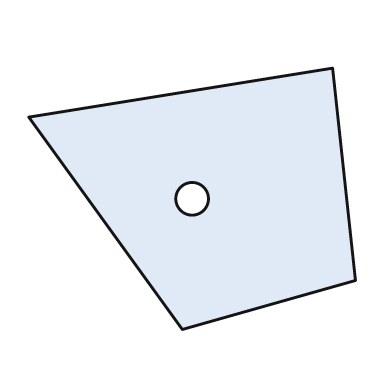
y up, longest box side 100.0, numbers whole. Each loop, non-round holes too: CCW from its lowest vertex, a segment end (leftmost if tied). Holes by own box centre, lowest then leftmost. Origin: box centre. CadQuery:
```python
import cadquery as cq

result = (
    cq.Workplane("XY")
    .moveTo(-3.0, -40.0)
    .lineTo(50.0, -25.0)
    .lineTo(43.0, 40.0)
    .lineTo(-50.0, 25.0)
    .close()
    .moveTo(0.0, 0.0)
    .circle(5.0)
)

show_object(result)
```